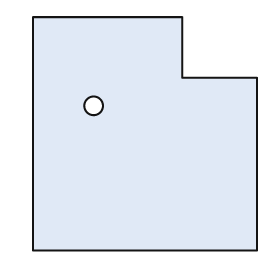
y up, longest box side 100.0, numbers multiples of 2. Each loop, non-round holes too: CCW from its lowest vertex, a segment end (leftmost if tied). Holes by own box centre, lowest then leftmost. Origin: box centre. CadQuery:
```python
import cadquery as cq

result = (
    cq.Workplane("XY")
    .moveTo(-48.0, -50.0)
    .lineTo(48.0, -50.0)
    .lineTo(48.0, 24.0)
    .lineTo(16.0, 24.0)
    .lineTo(16.0, 50.0)
    .lineTo(-48.0, 50.0)
    .close()
    .moveTo(-22.0, 12.0)
    .circle(4.0)
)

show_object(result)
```